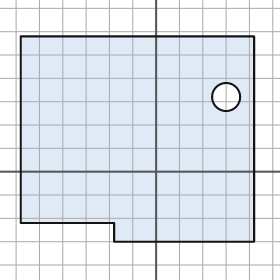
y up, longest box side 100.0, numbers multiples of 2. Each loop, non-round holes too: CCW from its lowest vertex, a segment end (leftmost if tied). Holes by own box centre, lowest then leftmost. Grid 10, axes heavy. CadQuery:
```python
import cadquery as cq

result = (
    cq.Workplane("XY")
    .moveTo(-18.0, -30.0)
    .lineTo(42.0, -30.0)
    .lineTo(42.0, 58.0)
    .lineTo(-58.0, 58.0)
    .lineTo(-58.0, -22.0)
    .lineTo(-18.0, -22.0)
    .close()
    .moveTo(30.0, 32.0)
    .circle(6.0)
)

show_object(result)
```